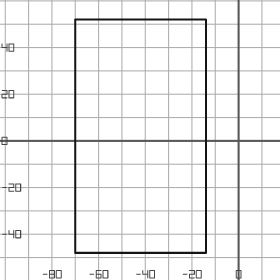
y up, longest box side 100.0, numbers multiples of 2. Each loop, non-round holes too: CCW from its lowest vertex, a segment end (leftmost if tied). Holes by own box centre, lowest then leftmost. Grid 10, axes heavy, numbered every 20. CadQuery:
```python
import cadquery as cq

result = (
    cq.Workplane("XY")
    .moveTo(-70.0, -48.0)
    .lineTo(-14.0, -48.0)
    .lineTo(-14.0, 52.0)
    .lineTo(-70.0, 52.0)
    .close()
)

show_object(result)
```